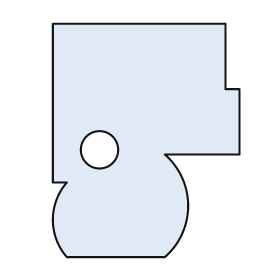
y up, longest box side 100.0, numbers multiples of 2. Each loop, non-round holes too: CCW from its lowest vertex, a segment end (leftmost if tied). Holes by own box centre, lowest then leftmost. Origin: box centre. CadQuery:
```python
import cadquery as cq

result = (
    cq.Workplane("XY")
    .moveTo(-34.0, -50.0)
    .lineTo(8.0, -50.0)
    .threePointArc((18.0, -28.0), (8.0, -6.0))
    .lineTo(40.0, -6.0)
    .lineTo(40.0, 22.0)
    .lineTo(34.0, 22.0)
    .lineTo(34.0, 50.0)
    .lineTo(-40.0, 50.0)
    .lineTo(-40.0, -18.0)
    .lineTo(-34.0, -18.0)
    .threePointArc((-40.0, -34.0), (-34.0, -50.0))
    .close()
    .moveTo(-20.0, -4.0)
    .circle(8.0)
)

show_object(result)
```